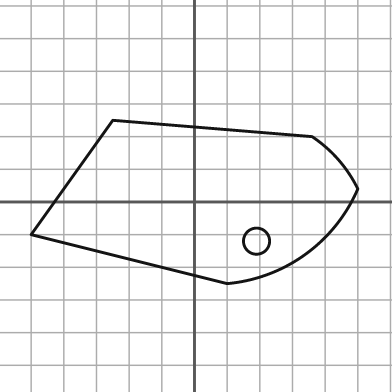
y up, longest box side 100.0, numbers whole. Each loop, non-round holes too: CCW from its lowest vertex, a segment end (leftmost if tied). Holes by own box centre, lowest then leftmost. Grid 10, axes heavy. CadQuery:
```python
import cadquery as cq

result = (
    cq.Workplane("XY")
    .moveTo(10.0, -25.0)
    .threePointArc((34.0, -16.0), (50.0, 4.0))
    .threePointArc((44.0, 13.0), (36.0, 20.0))
    .lineTo(-25.0, 25.0)
    .lineTo(-50.0, -10.0)
    .close()
    .moveTo(19.0, -12.0)
    .circle(4.0)
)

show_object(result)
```